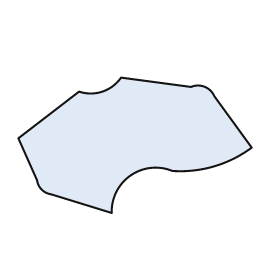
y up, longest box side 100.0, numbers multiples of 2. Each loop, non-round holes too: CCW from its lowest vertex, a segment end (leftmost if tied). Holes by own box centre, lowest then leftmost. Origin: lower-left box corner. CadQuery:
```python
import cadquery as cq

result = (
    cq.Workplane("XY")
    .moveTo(40.0, 0.0)
    .threePointArc((48.0, 16.0), (66.0, 18.0))
    .threePointArc((84.0, 20.0), (100.0, 28.0))
    .lineTo(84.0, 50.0)
    .threePointArc((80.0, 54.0), (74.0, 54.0))
    .lineTo(44.0, 58.0)
    .threePointArc((36.0, 52.0), (26.0, 52.0))
    .lineTo(0.0, 32.0)
    .lineTo(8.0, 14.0)
    .threePointArc((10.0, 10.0), (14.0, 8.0))
    .close()
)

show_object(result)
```